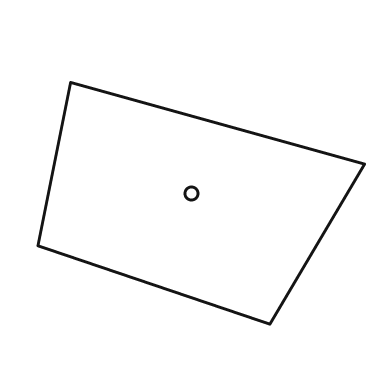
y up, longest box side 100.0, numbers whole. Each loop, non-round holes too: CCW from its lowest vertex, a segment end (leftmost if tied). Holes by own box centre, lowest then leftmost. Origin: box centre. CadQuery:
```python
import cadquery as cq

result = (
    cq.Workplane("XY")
    .moveTo(21.0, -37.0)
    .lineTo(50.0, 12.0)
    .lineTo(-40.0, 37.0)
    .lineTo(-50.0, -13.0)
    .close()
    .moveTo(-3.0, 3.0)
    .circle(2.0)
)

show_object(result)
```